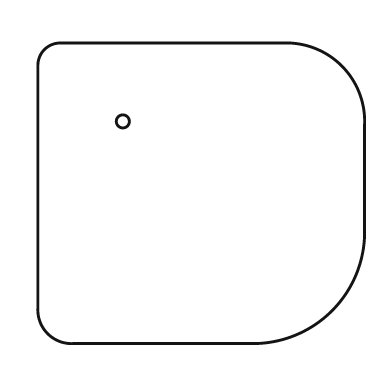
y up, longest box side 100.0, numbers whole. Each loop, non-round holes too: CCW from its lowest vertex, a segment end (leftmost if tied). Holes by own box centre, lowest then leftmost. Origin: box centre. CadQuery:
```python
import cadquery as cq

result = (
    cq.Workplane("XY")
    .moveTo(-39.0, -46.0)
    .lineTo(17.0, -46.0)
    .threePointArc((40.0, -36.0), (50.0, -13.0))
    .lineTo(50.0, 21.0)
    .threePointArc((43.0, 39.0), (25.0, 46.0))
    .lineTo(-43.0, 46.0)
    .threePointArc((-48.0, 44.0), (-50.0, 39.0))
    .lineTo(-50.0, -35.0)
    .threePointArc((-47.0, -43.0), (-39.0, -46.0))
    .close()
    .moveTo(-24.0, 22.0)
    .circle(2.0)
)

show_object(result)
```